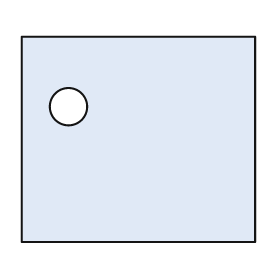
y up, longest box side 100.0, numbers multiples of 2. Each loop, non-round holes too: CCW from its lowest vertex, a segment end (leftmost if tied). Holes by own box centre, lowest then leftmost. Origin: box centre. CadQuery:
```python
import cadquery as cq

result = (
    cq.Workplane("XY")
    .moveTo(-50.0, -44.0)
    .lineTo(50.0, -44.0)
    .lineTo(50.0, 44.0)
    .lineTo(-50.0, 44.0)
    .close()
    .moveTo(-30.0, 14.0)
    .circle(8.0)
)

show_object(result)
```